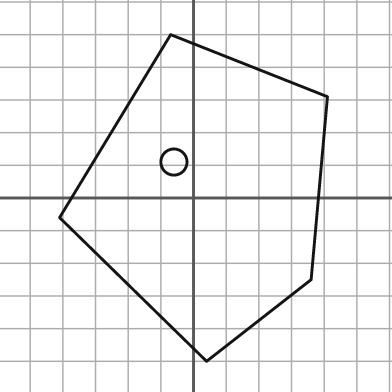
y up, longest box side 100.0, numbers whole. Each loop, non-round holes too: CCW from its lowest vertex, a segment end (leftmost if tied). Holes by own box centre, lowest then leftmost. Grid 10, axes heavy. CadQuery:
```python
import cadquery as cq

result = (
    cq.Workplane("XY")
    .moveTo(4.0, -50.0)
    .lineTo(36.0, -25.0)
    .lineTo(41.0, 31.0)
    .lineTo(-7.0, 50.0)
    .lineTo(-41.0, -6.0)
    .close()
    .moveTo(-6.0, 11.0)
    .circle(4.0)
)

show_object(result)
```